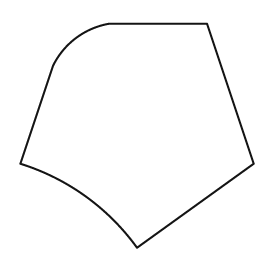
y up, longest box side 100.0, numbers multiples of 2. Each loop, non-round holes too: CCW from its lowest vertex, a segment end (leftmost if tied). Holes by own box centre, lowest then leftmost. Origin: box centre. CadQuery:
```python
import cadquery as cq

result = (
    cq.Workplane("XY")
    .moveTo(0.0, -48.0)
    .lineTo(50.0, -12.0)
    .lineTo(30.0, 48.0)
    .lineTo(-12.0, 48.0)
    .threePointArc((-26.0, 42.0), (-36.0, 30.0))
    .lineTo(-50.0, -12.0)
    .threePointArc((-22.0, -26.0), (0.0, -48.0))
    .close()
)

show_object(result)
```